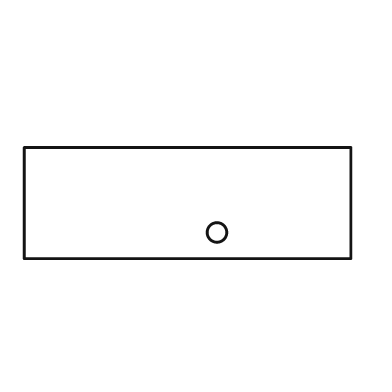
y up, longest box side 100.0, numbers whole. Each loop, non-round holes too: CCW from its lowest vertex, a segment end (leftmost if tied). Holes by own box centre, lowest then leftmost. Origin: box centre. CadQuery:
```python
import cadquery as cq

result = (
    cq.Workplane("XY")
    .moveTo(-50.0, -17.0)
    .lineTo(50.0, -17.0)
    .lineTo(50.0, 17.0)
    .lineTo(-50.0, 17.0)
    .close()
    .moveTo(9.0, -9.0)
    .circle(3.0)
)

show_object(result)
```